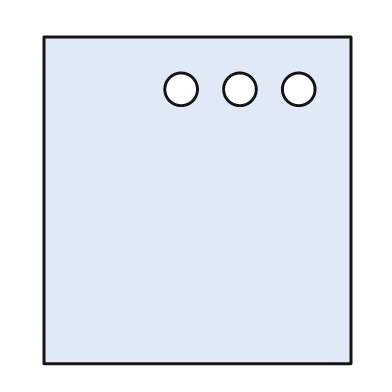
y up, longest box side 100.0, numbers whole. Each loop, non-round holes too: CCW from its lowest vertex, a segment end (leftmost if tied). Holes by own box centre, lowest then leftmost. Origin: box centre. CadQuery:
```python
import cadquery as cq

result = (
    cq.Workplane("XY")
    .moveTo(-47.0, -50.0)
    .lineTo(47.0, -50.0)
    .lineTo(47.0, 50.0)
    .lineTo(-47.0, 50.0)
    .close()
    .moveTo(-5.0, 34.0)
    .circle(5.0)
    .moveTo(13.0, 34.0)
    .circle(5.0)
    .moveTo(31.0, 34.0)
    .circle(5.0)
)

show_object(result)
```